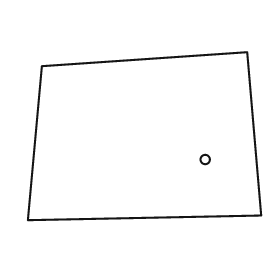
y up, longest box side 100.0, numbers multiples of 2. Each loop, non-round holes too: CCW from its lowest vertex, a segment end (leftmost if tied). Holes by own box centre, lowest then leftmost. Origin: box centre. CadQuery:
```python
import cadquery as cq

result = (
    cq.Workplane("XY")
    .moveTo(-50.0, -36.0)
    .lineTo(50.0, -34.0)
    .lineTo(44.0, 36.0)
    .lineTo(-44.0, 30.0)
    .close()
    .moveTo(26.0, -10.0)
    .circle(2.0)
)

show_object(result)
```